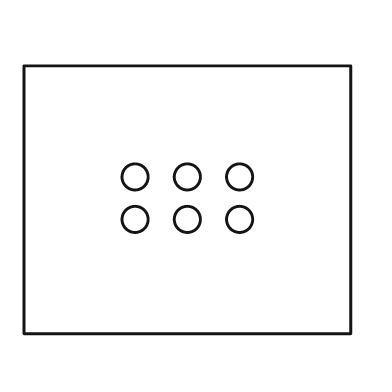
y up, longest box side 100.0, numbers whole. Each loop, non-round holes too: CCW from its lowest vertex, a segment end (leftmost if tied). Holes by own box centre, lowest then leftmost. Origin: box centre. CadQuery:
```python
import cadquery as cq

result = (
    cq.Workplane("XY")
    .moveTo(-50.0, -41.0)
    .lineTo(50.0, -41.0)
    .lineTo(50.0, 41.0)
    .lineTo(-50.0, 41.0)
    .close()
    .moveTo(-16.0, -6.0)
    .circle(4.0)
    .moveTo(0.0, -6.0)
    .circle(4.0)
    .moveTo(16.0, -6.0)
    .circle(4.0)
    .moveTo(-16.0, 7.0)
    .circle(4.0)
    .moveTo(0.0, 7.0)
    .circle(4.0)
    .moveTo(16.0, 7.0)
    .circle(4.0)
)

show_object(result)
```